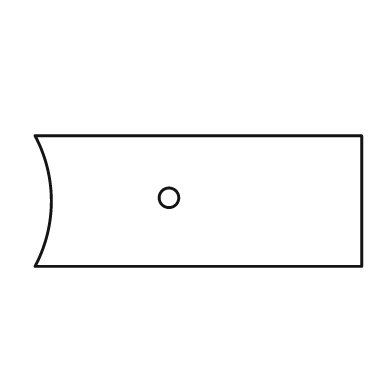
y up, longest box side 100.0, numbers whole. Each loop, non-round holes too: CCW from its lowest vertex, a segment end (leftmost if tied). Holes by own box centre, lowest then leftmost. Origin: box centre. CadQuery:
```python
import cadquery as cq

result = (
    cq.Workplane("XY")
    .moveTo(-50.0, -20.0)
    .lineTo(50.0, -20.0)
    .lineTo(50.0, 20.0)
    .lineTo(-50.0, 20.0)
    .threePointArc((-45.0, 0.0), (-50.0, -20.0))
    .close()
    .moveTo(-9.0, 1.0)
    .circle(3.0)
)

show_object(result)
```